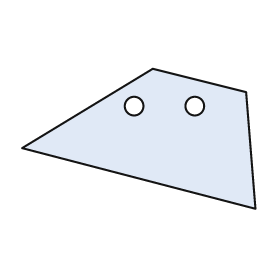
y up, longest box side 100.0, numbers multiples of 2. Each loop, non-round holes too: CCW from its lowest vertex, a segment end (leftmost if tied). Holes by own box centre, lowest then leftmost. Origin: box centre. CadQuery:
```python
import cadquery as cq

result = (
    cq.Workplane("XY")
    .moveTo(50.0, -30.0)
    .lineTo(46.0, 20.0)
    .lineTo(6.0, 30.0)
    .lineTo(-50.0, -4.0)
    .close()
    .moveTo(-2.0, 14.0)
    .circle(4.0)
    .moveTo(24.0, 14.0)
    .circle(4.0)
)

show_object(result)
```